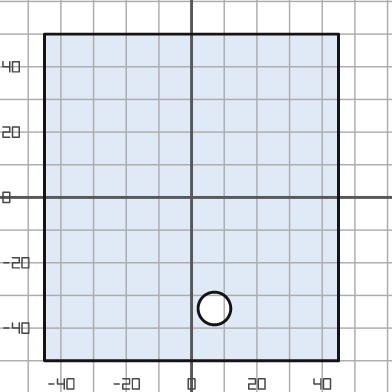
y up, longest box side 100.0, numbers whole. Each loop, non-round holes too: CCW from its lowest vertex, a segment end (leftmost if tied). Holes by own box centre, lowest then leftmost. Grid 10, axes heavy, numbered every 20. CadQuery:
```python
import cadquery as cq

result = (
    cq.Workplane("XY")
    .moveTo(-45.0, -50.0)
    .lineTo(45.0, -50.0)
    .lineTo(45.0, 50.0)
    .lineTo(-45.0, 50.0)
    .close()
    .moveTo(7.0, -34.0)
    .circle(5.0)
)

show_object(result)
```